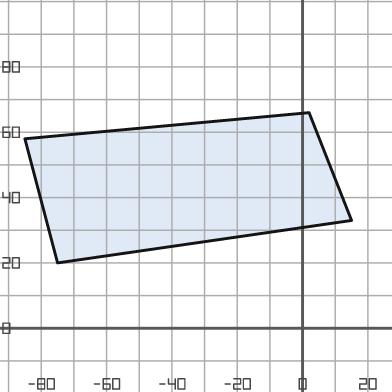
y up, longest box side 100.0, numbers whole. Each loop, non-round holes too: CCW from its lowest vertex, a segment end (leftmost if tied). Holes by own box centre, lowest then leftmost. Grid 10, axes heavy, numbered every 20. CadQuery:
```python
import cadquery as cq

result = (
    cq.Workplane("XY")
    .moveTo(-75.0, 20.0)
    .lineTo(15.0, 33.0)
    .lineTo(2.0, 66.0)
    .lineTo(-85.0, 58.0)
    .close()
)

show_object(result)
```